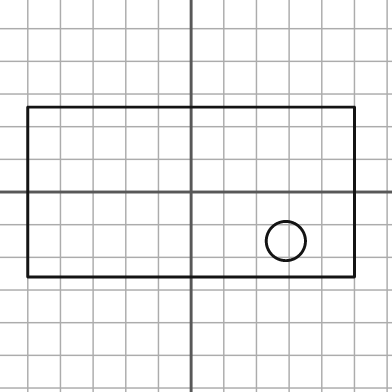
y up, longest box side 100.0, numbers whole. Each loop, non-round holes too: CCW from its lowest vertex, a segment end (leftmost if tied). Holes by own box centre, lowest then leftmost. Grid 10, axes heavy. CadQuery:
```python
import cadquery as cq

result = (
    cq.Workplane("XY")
    .moveTo(-50.0, -26.0)
    .lineTo(50.0, -26.0)
    .lineTo(50.0, 26.0)
    .lineTo(-50.0, 26.0)
    .close()
    .moveTo(29.0, -15.0)
    .circle(6.0)
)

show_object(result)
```